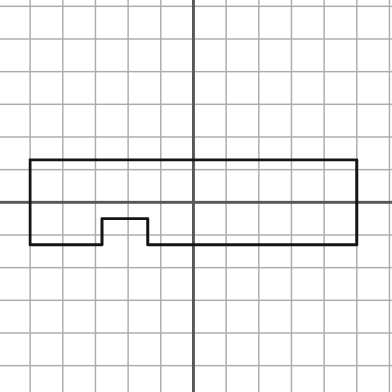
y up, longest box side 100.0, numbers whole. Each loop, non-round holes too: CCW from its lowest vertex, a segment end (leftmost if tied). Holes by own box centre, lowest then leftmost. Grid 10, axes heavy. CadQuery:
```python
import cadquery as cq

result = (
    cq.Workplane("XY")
    .moveTo(-50.0, -13.0)
    .lineTo(-28.0, -13.0)
    .lineTo(-28.0, -5.0)
    .lineTo(-14.0, -5.0)
    .lineTo(-14.0, -13.0)
    .lineTo(50.0, -13.0)
    .lineTo(50.0, 13.0)
    .lineTo(-50.0, 13.0)
    .close()
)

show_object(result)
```